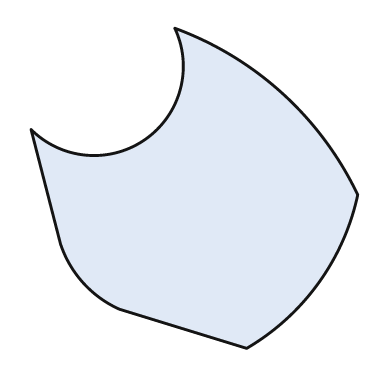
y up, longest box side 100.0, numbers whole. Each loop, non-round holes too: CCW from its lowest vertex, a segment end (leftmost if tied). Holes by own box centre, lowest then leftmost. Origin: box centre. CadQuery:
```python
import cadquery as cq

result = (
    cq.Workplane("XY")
    .moveTo(16.0, -49.0)
    .threePointArc((38.0, -29.0), (50.0, -2.0))
    .threePointArc((27.0, 29.0), (-6.0, 49.0))
    .threePointArc((-15.0, 15.0), (-50.0, 18.0))
    .lineTo(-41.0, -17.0)
    .threePointArc((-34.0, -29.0), (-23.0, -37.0))
    .close()
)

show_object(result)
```